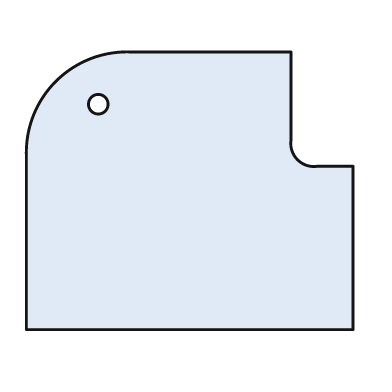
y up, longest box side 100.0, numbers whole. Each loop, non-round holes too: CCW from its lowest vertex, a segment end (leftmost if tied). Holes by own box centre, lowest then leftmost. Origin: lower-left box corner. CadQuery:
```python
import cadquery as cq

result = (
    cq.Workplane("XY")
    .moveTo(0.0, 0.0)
    .lineTo(100.0, 0.0)
    .lineTo(100.0, 50.0)
    .lineTo(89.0, 50.0)
    .threePointArc((83.0, 52.0), (81.0, 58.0))
    .lineTo(81.0, 85.0)
    .lineTo(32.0, 85.0)
    .threePointArc((9.0, 76.0), (0.0, 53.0))
    .close()
    .moveTo(22.0, 69.0)
    .circle(3.0)
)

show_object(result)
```